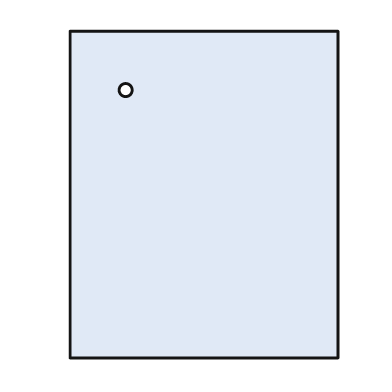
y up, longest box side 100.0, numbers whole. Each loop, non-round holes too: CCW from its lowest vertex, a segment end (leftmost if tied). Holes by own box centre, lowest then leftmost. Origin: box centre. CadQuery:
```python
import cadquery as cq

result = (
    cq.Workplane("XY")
    .moveTo(-41.0, -50.0)
    .lineTo(41.0, -50.0)
    .lineTo(41.0, 50.0)
    .lineTo(-41.0, 50.0)
    .close()
    .moveTo(-24.0, 32.0)
    .circle(2.0)
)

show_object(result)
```